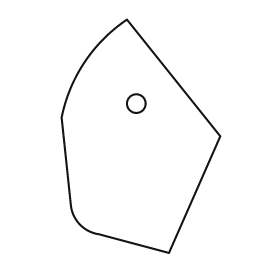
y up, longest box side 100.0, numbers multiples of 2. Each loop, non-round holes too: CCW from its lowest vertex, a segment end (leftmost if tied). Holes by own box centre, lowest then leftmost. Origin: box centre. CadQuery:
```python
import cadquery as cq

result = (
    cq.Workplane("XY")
    .moveTo(12.0, -50.0)
    .lineTo(34.0, 0.0)
    .lineTo(-6.0, 50.0)
    .threePointArc((-24.0, 32.0), (-34.0, 8.0))
    .lineTo(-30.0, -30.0)
    .threePointArc((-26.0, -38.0), (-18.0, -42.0))
    .close()
    .moveTo(-2.0, 14.0)
    .circle(4.0)
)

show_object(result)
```